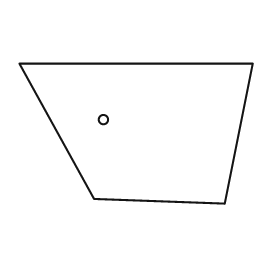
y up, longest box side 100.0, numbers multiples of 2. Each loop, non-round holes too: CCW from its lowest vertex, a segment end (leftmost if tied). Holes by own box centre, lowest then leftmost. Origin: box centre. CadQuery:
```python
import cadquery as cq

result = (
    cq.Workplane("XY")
    .moveTo(38.0, -30.0)
    .lineTo(50.0, 30.0)
    .lineTo(-50.0, 30.0)
    .lineTo(-18.0, -28.0)
    .close()
    .moveTo(-14.0, 6.0)
    .circle(2.0)
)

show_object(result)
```